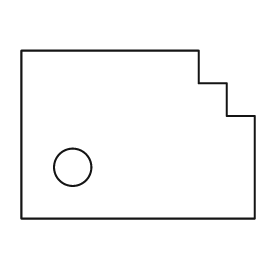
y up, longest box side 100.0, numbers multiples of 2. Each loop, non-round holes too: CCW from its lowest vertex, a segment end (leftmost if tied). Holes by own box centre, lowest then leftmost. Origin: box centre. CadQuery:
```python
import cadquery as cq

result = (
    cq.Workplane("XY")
    .moveTo(-50.0, -36.0)
    .lineTo(50.0, -36.0)
    .lineTo(50.0, 8.0)
    .lineTo(38.0, 8.0)
    .lineTo(38.0, 22.0)
    .lineTo(26.0, 22.0)
    .lineTo(26.0, 36.0)
    .lineTo(-50.0, 36.0)
    .close()
    .moveTo(-28.0, -14.0)
    .circle(8.0)
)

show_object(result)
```